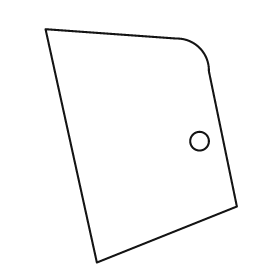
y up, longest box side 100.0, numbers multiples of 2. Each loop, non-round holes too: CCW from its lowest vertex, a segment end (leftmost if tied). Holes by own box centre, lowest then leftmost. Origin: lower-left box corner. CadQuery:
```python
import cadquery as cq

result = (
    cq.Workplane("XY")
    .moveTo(22.0, 0.0)
    .lineTo(82.0, 24.0)
    .lineTo(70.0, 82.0)
    .threePointArc((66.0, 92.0), (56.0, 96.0))
    .lineTo(0.0, 100.0)
    .close()
    .moveTo(66.0, 52.0)
    .circle(4.0)
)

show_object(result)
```